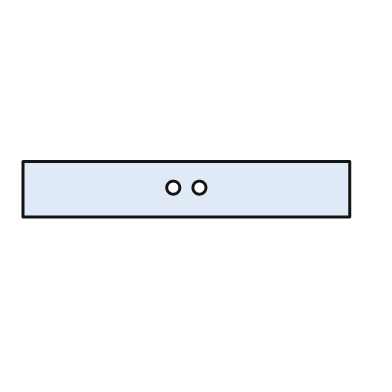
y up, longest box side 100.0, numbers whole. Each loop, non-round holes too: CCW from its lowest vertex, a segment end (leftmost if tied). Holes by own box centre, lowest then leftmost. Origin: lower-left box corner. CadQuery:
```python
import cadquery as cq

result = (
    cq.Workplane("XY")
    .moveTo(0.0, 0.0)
    .lineTo(100.0, 0.0)
    .lineTo(100.0, 17.0)
    .lineTo(0.0, 17.0)
    .close()
    .moveTo(46.0, 9.0)
    .circle(2.0)
    .moveTo(54.0, 9.0)
    .circle(2.0)
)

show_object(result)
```